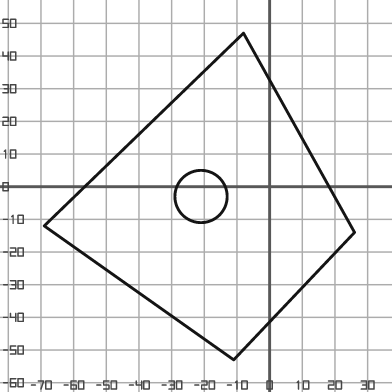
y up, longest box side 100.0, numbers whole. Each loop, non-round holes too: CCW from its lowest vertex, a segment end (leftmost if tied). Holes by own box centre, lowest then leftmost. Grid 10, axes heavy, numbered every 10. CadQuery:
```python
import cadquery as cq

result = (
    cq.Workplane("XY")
    .moveTo(-11.0, -53.0)
    .lineTo(26.0, -14.0)
    .lineTo(-8.0, 47.0)
    .lineTo(-69.0, -12.0)
    .close()
    .moveTo(-21.0, -3.0)
    .circle(8.0)
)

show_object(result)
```